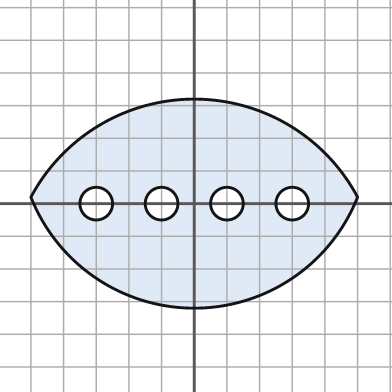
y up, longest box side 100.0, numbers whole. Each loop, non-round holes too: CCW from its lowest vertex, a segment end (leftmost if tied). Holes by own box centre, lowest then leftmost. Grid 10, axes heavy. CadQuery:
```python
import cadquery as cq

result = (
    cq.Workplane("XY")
    .moveTo(-50.0, 2.0)
    .threePointArc((0.0, -32.0), (50.0, 2.0))
    .threePointArc((0.0, 32.0), (-50.0, 2.0))
    .close()
    .moveTo(-30.0, 0.0)
    .circle(5.0)
    .moveTo(-10.0, 0.0)
    .circle(5.0)
    .moveTo(10.0, 0.0)
    .circle(5.0)
    .moveTo(30.0, 0.0)
    .circle(5.0)
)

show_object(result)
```